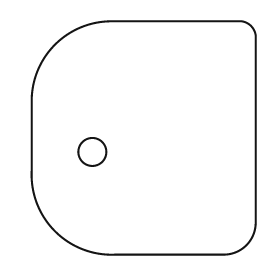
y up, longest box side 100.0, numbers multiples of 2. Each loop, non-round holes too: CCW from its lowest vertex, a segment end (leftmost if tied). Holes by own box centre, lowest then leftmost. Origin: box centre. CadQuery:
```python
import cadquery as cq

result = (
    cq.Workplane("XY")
    .moveTo(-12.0, -50.0)
    .lineTo(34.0, -50.0)
    .threePointArc((44.0, -46.0), (48.0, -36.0))
    .lineTo(48.0, 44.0)
    .threePointArc((46.0, 48.0), (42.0, 50.0))
    .lineTo(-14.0, 50.0)
    .threePointArc((-38.0, 40.0), (-48.0, 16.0))
    .lineTo(-48.0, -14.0)
    .threePointArc((-38.0, -40.0), (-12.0, -50.0))
    .close()
    .moveTo(-22.0, -6.0)
    .circle(6.0)
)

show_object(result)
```